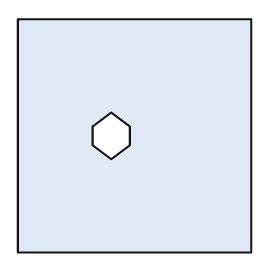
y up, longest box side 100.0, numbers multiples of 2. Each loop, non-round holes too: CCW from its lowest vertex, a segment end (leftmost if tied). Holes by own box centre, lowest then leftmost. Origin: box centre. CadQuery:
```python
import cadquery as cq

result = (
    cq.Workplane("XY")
    .moveTo(-50.0, -50.0)
    .lineTo(50.0, -50.0)
    .lineTo(50.0, 50.0)
    .lineTo(-50.0, 50.0)
    .close()
    .moveTo(-10.0, -10.0)
    .lineTo(-2.0, -4.0)
    .lineTo(-2.0, 4.0)
    .lineTo(-10.0, 10.0)
    .lineTo(-18.0, 4.0)
    .lineTo(-18.0, -4.0)
    .close()
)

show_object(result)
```